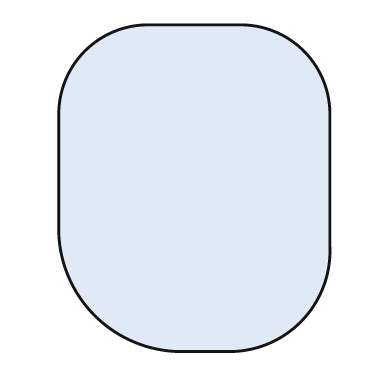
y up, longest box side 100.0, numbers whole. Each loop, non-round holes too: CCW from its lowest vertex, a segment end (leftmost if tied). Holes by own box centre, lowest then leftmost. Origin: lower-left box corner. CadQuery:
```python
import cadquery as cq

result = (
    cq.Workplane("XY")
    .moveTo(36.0, 0.0)
    .lineTo(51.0, 0.0)
    .threePointArc((74.0, 9.0), (83.0, 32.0))
    .lineTo(83.0, 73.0)
    .threePointArc((75.0, 92.0), (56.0, 100.0))
    .lineTo(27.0, 100.0)
    .threePointArc((8.0, 92.0), (0.0, 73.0))
    .lineTo(0.0, 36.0)
    .threePointArc((11.0, 11.0), (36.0, 0.0))
    .close()
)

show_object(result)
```